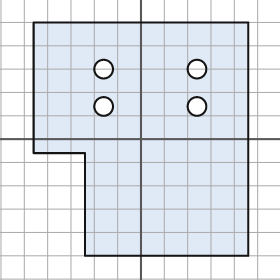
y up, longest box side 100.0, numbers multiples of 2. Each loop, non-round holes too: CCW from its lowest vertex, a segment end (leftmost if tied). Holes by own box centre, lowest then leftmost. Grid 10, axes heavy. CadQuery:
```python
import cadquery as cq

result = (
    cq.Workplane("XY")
    .moveTo(-24.0, -50.0)
    .lineTo(46.0, -50.0)
    .lineTo(46.0, 50.0)
    .lineTo(-46.0, 50.0)
    .lineTo(-46.0, -6.0)
    .lineTo(-24.0, -6.0)
    .close()
    .moveTo(-16.0, 14.0)
    .circle(4.0)
    .moveTo(24.0, 14.0)
    .circle(4.0)
    .moveTo(-16.0, 30.0)
    .circle(4.0)
    .moveTo(24.0, 30.0)
    .circle(4.0)
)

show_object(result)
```